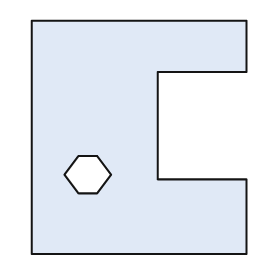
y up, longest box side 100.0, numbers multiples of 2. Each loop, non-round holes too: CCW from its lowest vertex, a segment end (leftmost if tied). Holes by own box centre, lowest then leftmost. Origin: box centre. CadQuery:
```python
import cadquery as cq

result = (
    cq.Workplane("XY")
    .moveTo(-46.0, -50.0)
    .lineTo(46.0, -50.0)
    .lineTo(46.0, -18.0)
    .lineTo(8.0, -18.0)
    .lineTo(8.0, 28.0)
    .lineTo(46.0, 28.0)
    .lineTo(46.0, 50.0)
    .lineTo(-46.0, 50.0)
    .close()
    .moveTo(-26.0, -24.0)
    .lineTo(-18.0, -24.0)
    .lineTo(-12.0, -16.0)
    .lineTo(-18.0, -8.0)
    .lineTo(-26.0, -8.0)
    .lineTo(-32.0, -16.0)
    .close()
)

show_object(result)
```